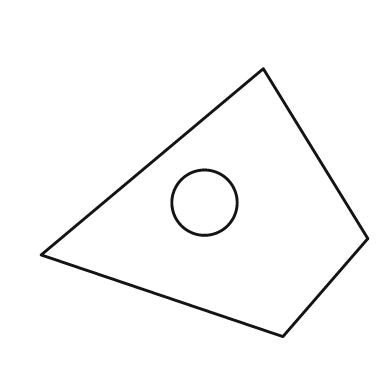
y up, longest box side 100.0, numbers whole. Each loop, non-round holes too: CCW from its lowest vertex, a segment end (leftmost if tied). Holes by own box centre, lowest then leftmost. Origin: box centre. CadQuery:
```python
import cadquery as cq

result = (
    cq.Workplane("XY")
    .moveTo(24.0, -41.0)
    .lineTo(50.0, -11.0)
    .lineTo(18.0, 41.0)
    .lineTo(-50.0, -16.0)
    .close()
    .moveTo(0.0, 0.0)
    .circle(10.0)
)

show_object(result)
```